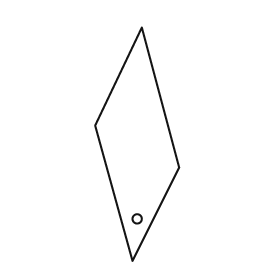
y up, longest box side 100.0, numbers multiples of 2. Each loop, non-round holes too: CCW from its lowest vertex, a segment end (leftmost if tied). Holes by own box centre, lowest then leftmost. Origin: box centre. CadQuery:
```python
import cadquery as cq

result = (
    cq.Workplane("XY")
    .moveTo(-2.0, -50.0)
    .lineTo(18.0, -10.0)
    .lineTo(2.0, 50.0)
    .lineTo(-18.0, 8.0)
    .close()
    .moveTo(0.0, -32.0)
    .circle(2.0)
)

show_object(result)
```